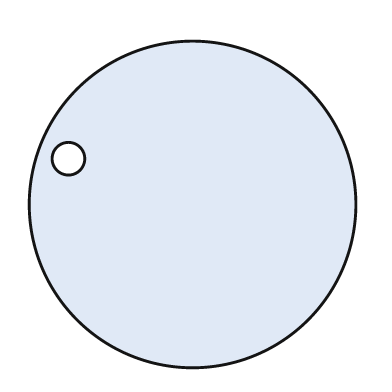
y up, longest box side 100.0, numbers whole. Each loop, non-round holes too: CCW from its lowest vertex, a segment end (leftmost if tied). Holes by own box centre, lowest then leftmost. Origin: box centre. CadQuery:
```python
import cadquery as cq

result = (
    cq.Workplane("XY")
    .moveTo(0.0, 0.0)
    .circle(50.0)
    .moveTo(-38.0, 14.0)
    .circle(5.0)
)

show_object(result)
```